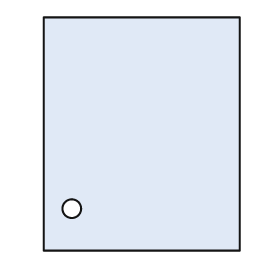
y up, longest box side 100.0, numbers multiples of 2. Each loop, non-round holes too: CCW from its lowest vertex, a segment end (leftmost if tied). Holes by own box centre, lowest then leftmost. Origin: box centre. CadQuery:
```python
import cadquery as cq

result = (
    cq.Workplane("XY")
    .moveTo(-42.0, -50.0)
    .lineTo(42.0, -50.0)
    .lineTo(42.0, 50.0)
    .lineTo(-42.0, 50.0)
    .close()
    .moveTo(-30.0, -32.0)
    .circle(4.0)
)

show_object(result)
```